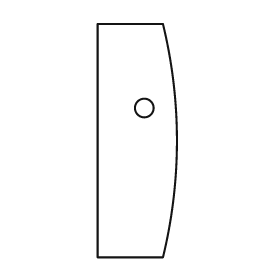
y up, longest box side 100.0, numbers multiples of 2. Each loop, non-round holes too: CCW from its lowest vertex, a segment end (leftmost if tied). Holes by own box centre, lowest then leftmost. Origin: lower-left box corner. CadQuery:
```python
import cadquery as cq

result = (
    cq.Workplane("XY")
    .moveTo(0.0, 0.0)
    .lineTo(28.0, 0.0)
    .threePointArc((34.0, 50.0), (28.0, 100.0))
    .lineTo(0.0, 100.0)
    .close()
    .moveTo(20.0, 64.0)
    .circle(4.0)
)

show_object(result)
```